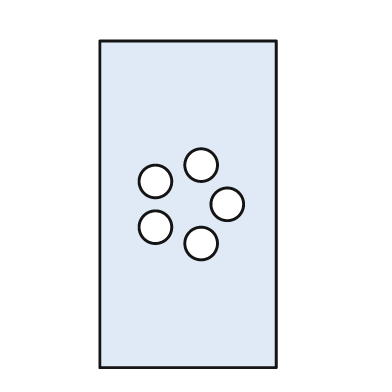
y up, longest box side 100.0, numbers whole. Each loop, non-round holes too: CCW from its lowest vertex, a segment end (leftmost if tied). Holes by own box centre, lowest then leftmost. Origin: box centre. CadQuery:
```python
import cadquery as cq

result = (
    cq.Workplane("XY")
    .moveTo(-27.0, -50.0)
    .lineTo(27.0, -50.0)
    .lineTo(27.0, 50.0)
    .lineTo(-27.0, 50.0)
    .close()
    .moveTo(4.0, -12.0)
    .circle(5.0)
    .moveTo(-10.0, -7.0)
    .circle(5.0)
    .moveTo(12.0, 0.0)
    .circle(5.0)
    .moveTo(-10.0, 7.0)
    .circle(5.0)
    .moveTo(4.0, 12.0)
    .circle(5.0)
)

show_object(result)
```